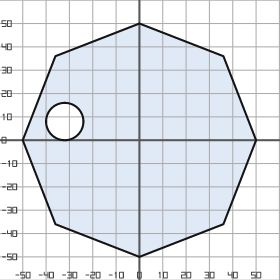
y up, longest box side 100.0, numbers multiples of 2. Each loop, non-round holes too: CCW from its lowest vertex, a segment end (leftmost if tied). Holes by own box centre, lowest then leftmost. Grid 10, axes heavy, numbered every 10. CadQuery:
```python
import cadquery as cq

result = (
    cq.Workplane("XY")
    .moveTo(0.0, -50.0)
    .lineTo(36.0, -36.0)
    .lineTo(50.0, 0.0)
    .lineTo(36.0, 36.0)
    .lineTo(0.0, 50.0)
    .lineTo(-36.0, 36.0)
    .lineTo(-50.0, 0.0)
    .lineTo(-36.0, -36.0)
    .close()
    .moveTo(-32.0, 8.0)
    .circle(8.0)
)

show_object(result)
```